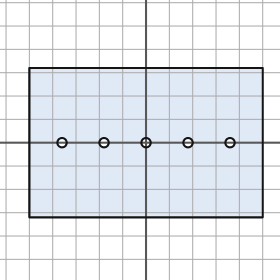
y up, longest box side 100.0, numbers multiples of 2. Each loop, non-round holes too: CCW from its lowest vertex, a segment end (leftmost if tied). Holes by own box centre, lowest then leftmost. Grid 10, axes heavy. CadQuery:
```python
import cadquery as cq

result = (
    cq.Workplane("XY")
    .moveTo(-50.0, -32.0)
    .lineTo(50.0, -32.0)
    .lineTo(50.0, 32.0)
    .lineTo(-50.0, 32.0)
    .close()
    .moveTo(-36.0, 0.0)
    .circle(2.0)
    .moveTo(-18.0, 0.0)
    .circle(2.0)
    .moveTo(0.0, 0.0)
    .circle(2.0)
    .moveTo(18.0, 0.0)
    .circle(2.0)
    .moveTo(36.0, 0.0)
    .circle(2.0)
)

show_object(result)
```